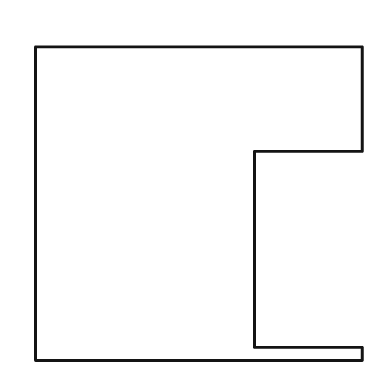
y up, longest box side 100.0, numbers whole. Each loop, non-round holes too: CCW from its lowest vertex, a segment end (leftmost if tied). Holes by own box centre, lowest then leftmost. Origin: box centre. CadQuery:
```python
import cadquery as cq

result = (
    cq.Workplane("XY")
    .moveTo(-50.0, -48.0)
    .lineTo(50.0, -48.0)
    .lineTo(50.0, -44.0)
    .lineTo(17.0, -44.0)
    .lineTo(17.0, 16.0)
    .lineTo(50.0, 16.0)
    .lineTo(50.0, 48.0)
    .lineTo(-50.0, 48.0)
    .close()
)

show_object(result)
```